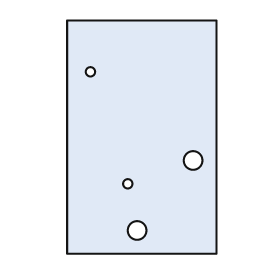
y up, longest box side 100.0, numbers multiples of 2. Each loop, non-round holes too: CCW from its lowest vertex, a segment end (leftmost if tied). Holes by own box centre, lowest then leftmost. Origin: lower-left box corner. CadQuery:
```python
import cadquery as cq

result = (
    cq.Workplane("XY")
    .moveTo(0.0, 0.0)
    .lineTo(64.0, 0.0)
    .lineTo(64.0, 100.0)
    .lineTo(0.0, 100.0)
    .close()
    .moveTo(30.0, 10.0)
    .circle(4.0)
    .moveTo(26.0, 30.0)
    .circle(2.0)
    .moveTo(54.0, 40.0)
    .circle(4.0)
    .moveTo(10.0, 78.0)
    .circle(2.0)
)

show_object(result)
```